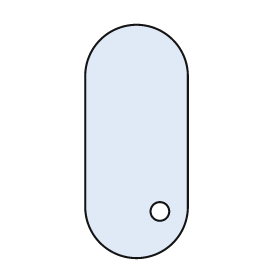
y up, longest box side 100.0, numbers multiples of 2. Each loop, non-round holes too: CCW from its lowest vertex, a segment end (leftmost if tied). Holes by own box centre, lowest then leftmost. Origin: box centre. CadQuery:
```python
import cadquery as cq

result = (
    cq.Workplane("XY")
    .moveTo(-22.0, -28.0)
    .threePointArc((0.0, -50.0), (22.0, -28.0))
    .lineTo(22.0, 28.0)
    .threePointArc((0.0, 50.0), (-22.0, 28.0))
    .close()
    .moveTo(10.0, -30.0)
    .circle(4.0)
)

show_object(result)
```